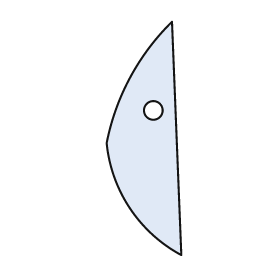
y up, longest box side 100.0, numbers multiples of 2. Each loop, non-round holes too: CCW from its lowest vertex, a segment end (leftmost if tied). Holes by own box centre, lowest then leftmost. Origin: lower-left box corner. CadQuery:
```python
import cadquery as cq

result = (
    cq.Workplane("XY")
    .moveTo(32.0, 0.0)
    .lineTo(28.0, 100.0)
    .threePointArc((10.0, 76.0), (0.0, 48.0))
    .threePointArc((10.0, 20.0), (32.0, 0.0))
    .close()
    .moveTo(20.0, 62.0)
    .circle(4.0)
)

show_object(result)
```